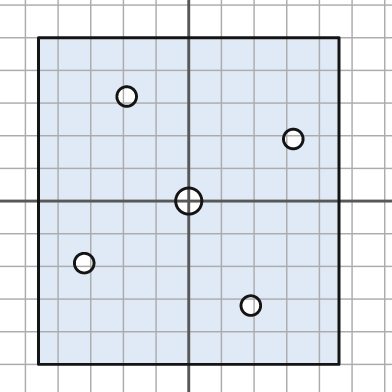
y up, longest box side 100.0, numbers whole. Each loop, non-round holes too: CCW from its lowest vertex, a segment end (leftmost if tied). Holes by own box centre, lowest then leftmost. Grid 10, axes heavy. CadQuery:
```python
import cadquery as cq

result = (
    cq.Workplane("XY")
    .moveTo(-46.0, -50.0)
    .lineTo(46.0, -50.0)
    .lineTo(46.0, 50.0)
    .lineTo(-46.0, 50.0)
    .close()
    .moveTo(19.0, -32.0)
    .circle(3.0)
    .moveTo(-32.0, -19.0)
    .circle(3.0)
    .moveTo(0.0, 0.0)
    .circle(4.0)
    .moveTo(32.0, 19.0)
    .circle(3.0)
    .moveTo(-19.0, 32.0)
    .circle(3.0)
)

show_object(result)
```